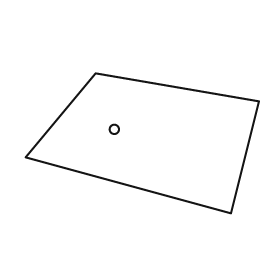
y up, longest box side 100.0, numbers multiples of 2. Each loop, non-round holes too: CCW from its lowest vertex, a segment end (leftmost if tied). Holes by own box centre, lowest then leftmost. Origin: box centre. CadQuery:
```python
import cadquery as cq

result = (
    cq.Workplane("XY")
    .moveTo(38.0, -30.0)
    .lineTo(50.0, 18.0)
    .lineTo(-20.0, 30.0)
    .lineTo(-50.0, -6.0)
    .close()
    .moveTo(-12.0, 6.0)
    .circle(2.0)
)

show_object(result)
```